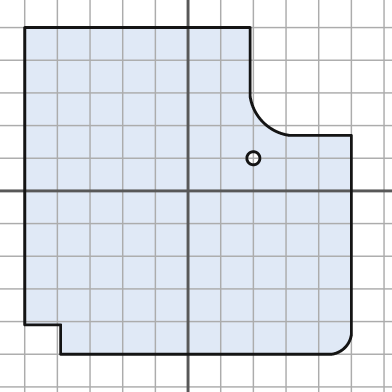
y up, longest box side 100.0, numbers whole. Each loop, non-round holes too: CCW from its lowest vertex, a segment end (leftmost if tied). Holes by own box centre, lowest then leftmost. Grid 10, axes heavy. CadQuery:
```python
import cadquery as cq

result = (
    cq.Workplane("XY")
    .moveTo(-39.0, -50.0)
    .lineTo(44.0, -50.0)
    .threePointArc((48.0, -48.0), (50.0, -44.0))
    .lineTo(50.0, 17.0)
    .lineTo(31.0, 17.0)
    .threePointArc((23.0, 21.0), (19.0, 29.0))
    .lineTo(19.0, 50.0)
    .lineTo(-50.0, 50.0)
    .lineTo(-50.0, -41.0)
    .lineTo(-39.0, -41.0)
    .close()
    .moveTo(20.0, 10.0)
    .circle(2.0)
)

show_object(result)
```